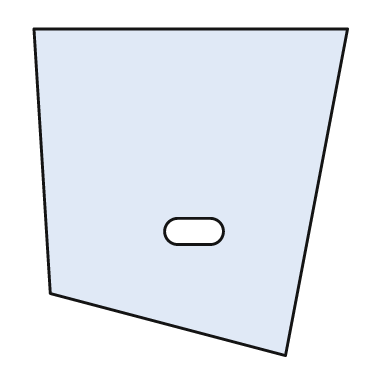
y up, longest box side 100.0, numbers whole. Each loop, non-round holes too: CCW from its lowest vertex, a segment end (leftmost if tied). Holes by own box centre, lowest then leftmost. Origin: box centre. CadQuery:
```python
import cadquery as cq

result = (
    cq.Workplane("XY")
    .moveTo(29.0, -50.0)
    .lineTo(48.0, 50.0)
    .lineTo(-48.0, 50.0)
    .lineTo(-43.0, -31.0)
    .close()
    .moveTo(-4.0, -16.0)
    .lineTo(6.0, -16.0)
    .threePointArc((10.0, -12.0), (6.0, -8.0))
    .lineTo(-4.0, -8.0)
    .threePointArc((-8.0, -12.0), (-4.0, -16.0))
    .close()
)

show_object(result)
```